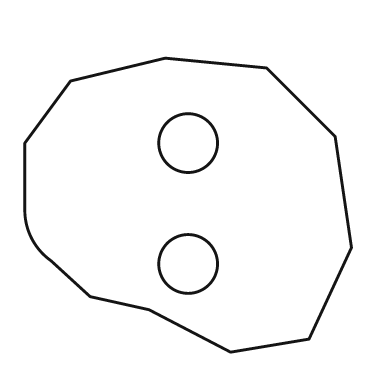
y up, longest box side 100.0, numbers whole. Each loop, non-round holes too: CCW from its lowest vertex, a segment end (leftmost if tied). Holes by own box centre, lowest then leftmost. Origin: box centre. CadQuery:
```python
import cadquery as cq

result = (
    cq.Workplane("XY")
    .moveTo(13.0, -45.0)
    .lineTo(37.0, -41.0)
    .lineTo(50.0, -13.0)
    .lineTo(45.0, 21.0)
    .lineTo(24.0, 42.0)
    .lineTo(-7.0, 45.0)
    .lineTo(-36.0, 38.0)
    .lineTo(-50.0, 19.0)
    .lineTo(-50.0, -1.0)
    .threePointArc((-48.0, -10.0), (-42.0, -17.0))
    .lineTo(-30.0, -28.0)
    .lineTo(-12.0, -32.0)
    .close()
    .moveTo(0.0, -18.0)
    .circle(9.0)
    .moveTo(0.0, 19.0)
    .circle(9.0)
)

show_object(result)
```